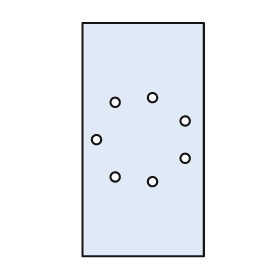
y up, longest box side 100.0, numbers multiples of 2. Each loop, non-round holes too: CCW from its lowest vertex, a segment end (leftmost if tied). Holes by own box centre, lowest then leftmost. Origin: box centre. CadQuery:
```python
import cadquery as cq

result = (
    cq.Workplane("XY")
    .moveTo(-26.0, -50.0)
    .lineTo(26.0, -50.0)
    .lineTo(26.0, 50.0)
    .lineTo(-26.0, 50.0)
    .close()
    .moveTo(4.0, -18.0)
    .circle(2.0)
    .moveTo(-12.0, -16.0)
    .circle(2.0)
    .moveTo(18.0, -8.0)
    .circle(2.0)
    .moveTo(-20.0, 0.0)
    .circle(2.0)
    .moveTo(18.0, 8.0)
    .circle(2.0)
    .moveTo(-12.0, 16.0)
    .circle(2.0)
    .moveTo(4.0, 18.0)
    .circle(2.0)
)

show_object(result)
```